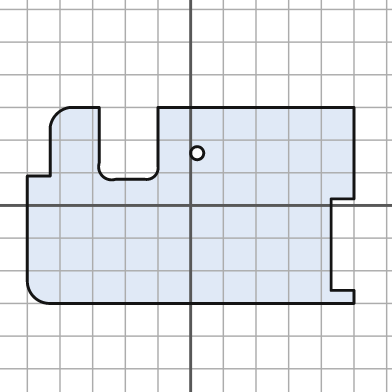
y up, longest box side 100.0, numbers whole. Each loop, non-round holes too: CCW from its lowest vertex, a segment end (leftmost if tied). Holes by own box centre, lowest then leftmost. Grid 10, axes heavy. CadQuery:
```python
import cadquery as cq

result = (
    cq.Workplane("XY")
    .moveTo(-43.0, -30.0)
    .lineTo(50.0, -30.0)
    .lineTo(50.0, -26.0)
    .lineTo(43.0, -26.0)
    .lineTo(43.0, 2.0)
    .lineTo(50.0, 2.0)
    .lineTo(50.0, 30.0)
    .lineTo(-10.0, 30.0)
    .lineTo(-10.0, 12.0)
    .threePointArc((-11.0, 9.0), (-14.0, 8.0))
    .lineTo(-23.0, 8.0)
    .threePointArc((-27.0, 9.0), (-28.0, 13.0))
    .lineTo(-28.0, 30.0)
    .lineTo(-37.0, 30.0)
    .threePointArc((-41.0, 28.0), (-43.0, 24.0))
    .lineTo(-43.0, 9.0)
    .lineTo(-50.0, 9.0)
    .lineTo(-50.0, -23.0)
    .threePointArc((-48.0, -28.0), (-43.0, -30.0))
    .close()
    .moveTo(2.0, 16.0)
    .circle(2.0)
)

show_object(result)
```